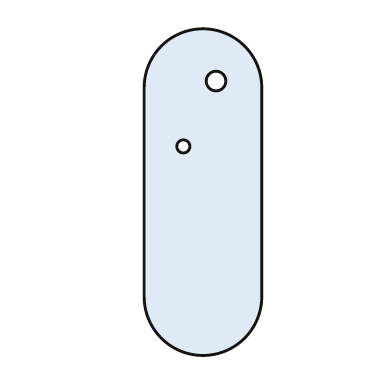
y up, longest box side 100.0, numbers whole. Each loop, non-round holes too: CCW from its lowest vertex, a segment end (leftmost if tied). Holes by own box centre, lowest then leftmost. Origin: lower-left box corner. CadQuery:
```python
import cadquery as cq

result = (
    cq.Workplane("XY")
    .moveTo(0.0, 18.0)
    .threePointArc((18.0, 0.0), (36.0, 18.0))
    .lineTo(36.0, 82.0)
    .threePointArc((18.0, 100.0), (0.0, 82.0))
    .close()
    .moveTo(12.0, 64.0)
    .circle(2.0)
    .moveTo(22.0, 84.0)
    .circle(3.0)
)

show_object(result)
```